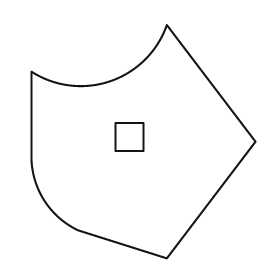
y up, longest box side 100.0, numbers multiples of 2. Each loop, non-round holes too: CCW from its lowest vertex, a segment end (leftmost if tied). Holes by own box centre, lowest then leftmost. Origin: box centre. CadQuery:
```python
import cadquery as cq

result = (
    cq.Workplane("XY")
    .moveTo(10.0, -50.0)
    .lineTo(48.0, 0.0)
    .lineTo(10.0, 50.0)
    .threePointArc((-14.0, 26.0), (-48.0, 30.0))
    .lineTo(-48.0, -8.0)
    .threePointArc((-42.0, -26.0), (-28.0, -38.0))
    .close()
    .moveTo(-12.0, -4.0)
    .lineTo(0.0, -4.0)
    .lineTo(0.0, 8.0)
    .lineTo(-12.0, 8.0)
    .close()
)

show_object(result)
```